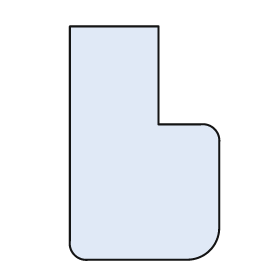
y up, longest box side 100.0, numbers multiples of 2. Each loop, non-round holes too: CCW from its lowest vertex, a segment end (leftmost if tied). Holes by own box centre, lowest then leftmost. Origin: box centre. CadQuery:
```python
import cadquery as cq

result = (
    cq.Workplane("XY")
    .moveTo(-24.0, -50.0)
    .lineTo(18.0, -50.0)
    .threePointArc((28.0, -46.0), (32.0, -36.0))
    .lineTo(32.0, 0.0)
    .threePointArc((30.0, 6.0), (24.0, 8.0))
    .lineTo(6.0, 8.0)
    .lineTo(6.0, 50.0)
    .lineTo(-32.0, 50.0)
    .lineTo(-32.0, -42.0)
    .threePointArc((-30.0, -48.0), (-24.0, -50.0))
    .close()
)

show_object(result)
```